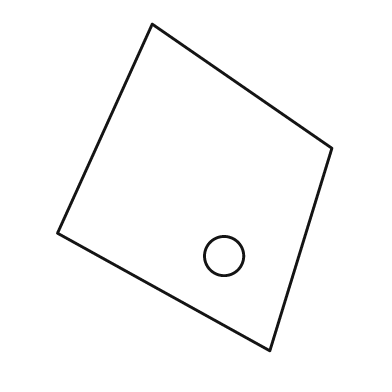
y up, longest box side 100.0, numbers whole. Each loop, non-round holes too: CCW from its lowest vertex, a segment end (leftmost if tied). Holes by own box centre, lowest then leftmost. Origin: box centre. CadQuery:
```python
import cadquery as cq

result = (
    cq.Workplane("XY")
    .moveTo(23.0, -50.0)
    .lineTo(42.0, 12.0)
    .lineTo(-13.0, 50.0)
    .lineTo(-42.0, -14.0)
    .close()
    .moveTo(9.0, -21.0)
    .circle(6.0)
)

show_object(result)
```